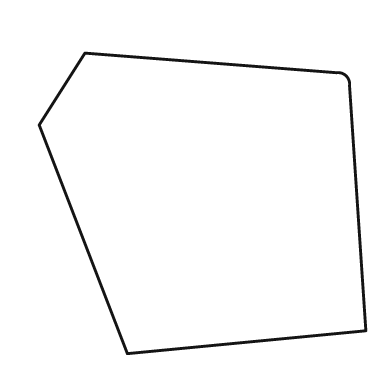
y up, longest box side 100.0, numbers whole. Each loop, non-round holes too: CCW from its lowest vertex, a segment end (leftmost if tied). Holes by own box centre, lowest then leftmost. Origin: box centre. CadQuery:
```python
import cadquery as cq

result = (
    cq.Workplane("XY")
    .moveTo(-23.0, -46.0)
    .lineTo(50.0, -39.0)
    .lineTo(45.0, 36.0)
    .threePointArc((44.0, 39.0), (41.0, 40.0))
    .lineTo(-36.0, 46.0)
    .lineTo(-50.0, 24.0)
    .close()
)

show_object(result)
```